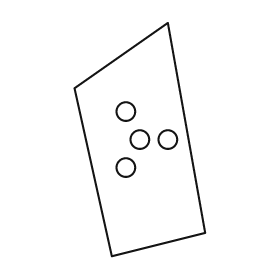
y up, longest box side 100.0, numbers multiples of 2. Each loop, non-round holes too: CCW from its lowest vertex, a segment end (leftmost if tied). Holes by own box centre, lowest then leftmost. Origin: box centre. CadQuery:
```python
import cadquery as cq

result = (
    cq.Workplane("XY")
    .moveTo(-12.0, -50.0)
    .lineTo(28.0, -40.0)
    .lineTo(12.0, 50.0)
    .lineTo(-28.0, 22.0)
    .close()
    .moveTo(-6.0, -12.0)
    .circle(4.0)
    .moveTo(0.0, 0.0)
    .circle(4.0)
    .moveTo(12.0, 0.0)
    .circle(4.0)
    .moveTo(-6.0, 12.0)
    .circle(4.0)
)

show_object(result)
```